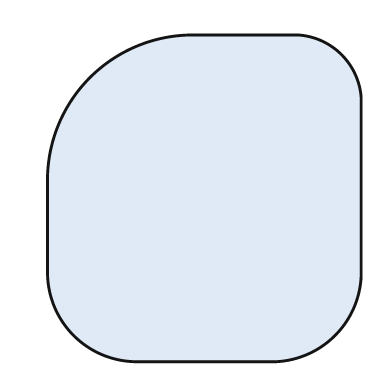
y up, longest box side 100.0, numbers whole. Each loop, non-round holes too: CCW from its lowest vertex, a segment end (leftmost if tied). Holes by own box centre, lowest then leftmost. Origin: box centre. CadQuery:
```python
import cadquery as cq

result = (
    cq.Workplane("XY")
    .moveTo(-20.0, -50.0)
    .lineTo(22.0, -50.0)
    .threePointArc((40.0, -42.0), (48.0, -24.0))
    .lineTo(48.0, 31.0)
    .threePointArc((42.0, 44.0), (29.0, 50.0))
    .lineTo(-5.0, 50.0)
    .threePointArc((-35.0, 37.0), (-48.0, 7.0))
    .lineTo(-48.0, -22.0)
    .threePointArc((-40.0, -42.0), (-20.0, -50.0))
    .close()
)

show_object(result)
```